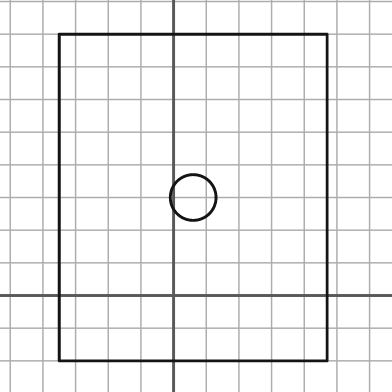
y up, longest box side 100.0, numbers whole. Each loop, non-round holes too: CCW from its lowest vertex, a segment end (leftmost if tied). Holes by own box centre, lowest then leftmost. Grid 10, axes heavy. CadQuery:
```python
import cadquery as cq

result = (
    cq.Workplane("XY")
    .moveTo(-35.0, -20.0)
    .lineTo(47.0, -20.0)
    .lineTo(47.0, 80.0)
    .lineTo(-35.0, 80.0)
    .close()
    .moveTo(6.0, 30.0)
    .circle(7.0)
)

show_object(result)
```